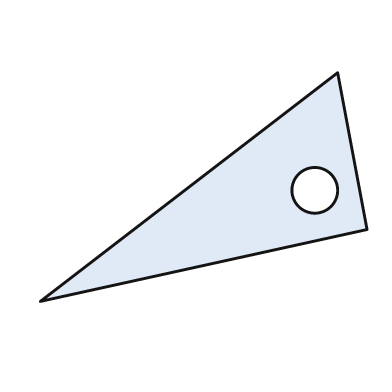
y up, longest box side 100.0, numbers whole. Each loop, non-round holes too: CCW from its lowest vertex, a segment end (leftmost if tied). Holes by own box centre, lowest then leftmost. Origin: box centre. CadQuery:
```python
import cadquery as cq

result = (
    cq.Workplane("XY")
    .moveTo(-50.0, -35.0)
    .lineTo(50.0, -13.0)
    .lineTo(41.0, 35.0)
    .close()
    .moveTo(34.0, -1.0)
    .circle(7.0)
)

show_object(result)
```